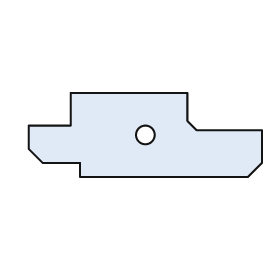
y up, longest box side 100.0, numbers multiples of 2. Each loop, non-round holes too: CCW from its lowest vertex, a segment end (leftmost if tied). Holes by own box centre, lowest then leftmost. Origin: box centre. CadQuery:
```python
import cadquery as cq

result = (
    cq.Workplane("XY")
    .moveTo(-28.0, -18.0)
    .lineTo(44.0, -18.0)
    .lineTo(50.0, -12.0)
    .lineTo(50.0, 2.0)
    .lineTo(22.0, 2.0)
    .lineTo(18.0, 6.0)
    .lineTo(18.0, 18.0)
    .lineTo(-32.0, 18.0)
    .lineTo(-32.0, 4.0)
    .lineTo(-50.0, 4.0)
    .lineTo(-50.0, -6.0)
    .lineTo(-44.0, -12.0)
    .lineTo(-28.0, -12.0)
    .close()
    .moveTo(0.0, 0.0)
    .circle(4.0)
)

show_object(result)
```